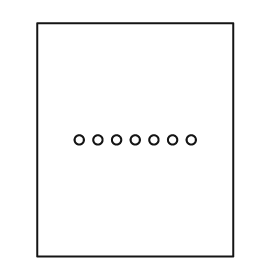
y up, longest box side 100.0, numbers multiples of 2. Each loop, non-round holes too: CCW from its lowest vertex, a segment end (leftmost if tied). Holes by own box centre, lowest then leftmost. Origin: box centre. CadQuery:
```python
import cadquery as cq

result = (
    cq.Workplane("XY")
    .moveTo(-42.0, -50.0)
    .lineTo(42.0, -50.0)
    .lineTo(42.0, 50.0)
    .lineTo(-42.0, 50.0)
    .close()
    .moveTo(-24.0, 0.0)
    .circle(2.0)
    .moveTo(-16.0, 0.0)
    .circle(2.0)
    .moveTo(-8.0, 0.0)
    .circle(2.0)
    .moveTo(0.0, 0.0)
    .circle(2.0)
    .moveTo(8.0, 0.0)
    .circle(2.0)
    .moveTo(16.0, 0.0)
    .circle(2.0)
    .moveTo(24.0, 0.0)
    .circle(2.0)
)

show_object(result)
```